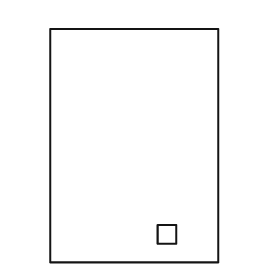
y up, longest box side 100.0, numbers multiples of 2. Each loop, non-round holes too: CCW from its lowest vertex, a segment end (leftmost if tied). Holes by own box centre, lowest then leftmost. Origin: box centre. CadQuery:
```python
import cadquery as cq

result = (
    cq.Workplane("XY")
    .moveTo(-36.0, -50.0)
    .lineTo(36.0, -50.0)
    .lineTo(36.0, 50.0)
    .lineTo(-36.0, 50.0)
    .close()
    .moveTo(10.0, -42.0)
    .lineTo(18.0, -42.0)
    .lineTo(18.0, -34.0)
    .lineTo(10.0, -34.0)
    .close()
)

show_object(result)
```